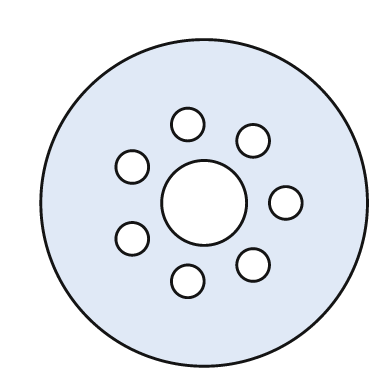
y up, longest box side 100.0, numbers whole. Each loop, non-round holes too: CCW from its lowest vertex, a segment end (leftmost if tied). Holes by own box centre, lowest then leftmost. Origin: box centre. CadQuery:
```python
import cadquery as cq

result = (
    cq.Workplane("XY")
    .moveTo(0.0, 0.0)
    .circle(50.0)
    .moveTo(-5.0, -24.0)
    .circle(5.0)
    .moveTo(15.0, -19.0)
    .circle(5.0)
    .moveTo(-22.0, -11.0)
    .circle(5.0)
    .moveTo(0.0, 0.0)
    .circle(13.0)
    .moveTo(25.0, 0.0)
    .circle(5.0)
    .moveTo(-22.0, 11.0)
    .circle(5.0)
    .moveTo(15.0, 19.0)
    .circle(5.0)
    .moveTo(-5.0, 24.0)
    .circle(5.0)
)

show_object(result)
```